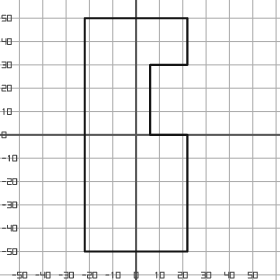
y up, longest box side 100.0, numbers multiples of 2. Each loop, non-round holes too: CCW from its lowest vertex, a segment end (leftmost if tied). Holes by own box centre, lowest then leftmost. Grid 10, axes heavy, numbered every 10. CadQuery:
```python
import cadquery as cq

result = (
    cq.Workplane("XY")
    .moveTo(-22.0, -50.0)
    .lineTo(22.0, -50.0)
    .lineTo(22.0, 0.0)
    .lineTo(6.0, 0.0)
    .lineTo(6.0, 30.0)
    .lineTo(22.0, 30.0)
    .lineTo(22.0, 50.0)
    .lineTo(-22.0, 50.0)
    .close()
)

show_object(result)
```